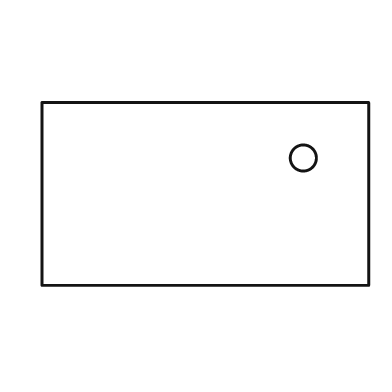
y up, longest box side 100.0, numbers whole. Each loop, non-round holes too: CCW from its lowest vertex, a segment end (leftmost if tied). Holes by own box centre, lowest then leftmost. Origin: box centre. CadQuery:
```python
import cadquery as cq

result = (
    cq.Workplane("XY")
    .moveTo(-50.0, -28.0)
    .lineTo(50.0, -28.0)
    .lineTo(50.0, 28.0)
    .lineTo(-50.0, 28.0)
    .close()
    .moveTo(30.0, 11.0)
    .circle(4.0)
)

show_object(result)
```